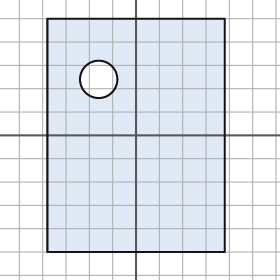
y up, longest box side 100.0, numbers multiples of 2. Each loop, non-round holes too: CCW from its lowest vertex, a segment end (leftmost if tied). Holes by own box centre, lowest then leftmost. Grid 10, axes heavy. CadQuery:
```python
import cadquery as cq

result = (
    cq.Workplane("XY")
    .moveTo(-38.0, -50.0)
    .lineTo(38.0, -50.0)
    .lineTo(38.0, 50.0)
    .lineTo(-38.0, 50.0)
    .close()
    .moveTo(-16.0, 24.0)
    .circle(8.0)
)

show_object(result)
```